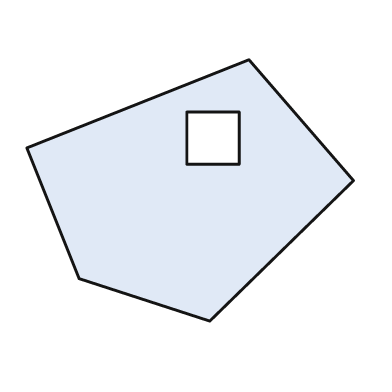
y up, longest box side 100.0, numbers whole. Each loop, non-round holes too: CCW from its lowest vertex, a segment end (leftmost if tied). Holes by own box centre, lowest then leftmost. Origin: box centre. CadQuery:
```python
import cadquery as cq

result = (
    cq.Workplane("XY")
    .moveTo(6.0, -40.0)
    .lineTo(50.0, 3.0)
    .lineTo(18.0, 40.0)
    .lineTo(-50.0, 13.0)
    .lineTo(-34.0, -27.0)
    .close()
    .moveTo(-1.0, 8.0)
    .lineTo(15.0, 8.0)
    .lineTo(15.0, 24.0)
    .lineTo(-1.0, 24.0)
    .close()
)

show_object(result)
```